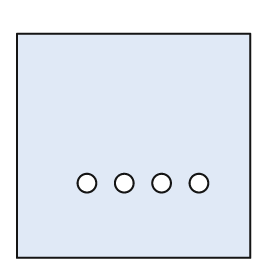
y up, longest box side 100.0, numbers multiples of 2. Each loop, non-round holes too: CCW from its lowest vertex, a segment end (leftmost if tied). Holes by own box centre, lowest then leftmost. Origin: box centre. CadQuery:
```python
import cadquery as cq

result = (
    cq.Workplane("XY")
    .moveTo(-50.0, -48.0)
    .lineTo(50.0, -48.0)
    .lineTo(50.0, 48.0)
    .lineTo(-50.0, 48.0)
    .close()
    .moveTo(-20.0, -16.0)
    .circle(4.0)
    .moveTo(-4.0, -16.0)
    .circle(4.0)
    .moveTo(12.0, -16.0)
    .circle(4.0)
    .moveTo(28.0, -16.0)
    .circle(4.0)
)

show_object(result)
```